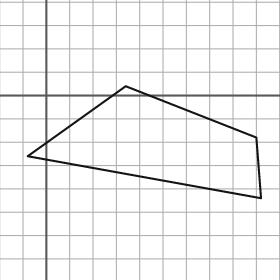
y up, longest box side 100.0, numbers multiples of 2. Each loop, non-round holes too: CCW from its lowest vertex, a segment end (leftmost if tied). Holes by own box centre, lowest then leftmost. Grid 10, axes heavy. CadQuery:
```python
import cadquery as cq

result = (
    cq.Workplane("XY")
    .moveTo(92.0, -44.0)
    .lineTo(90.0, -18.0)
    .lineTo(34.0, 4.0)
    .lineTo(-8.0, -26.0)
    .close()
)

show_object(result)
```